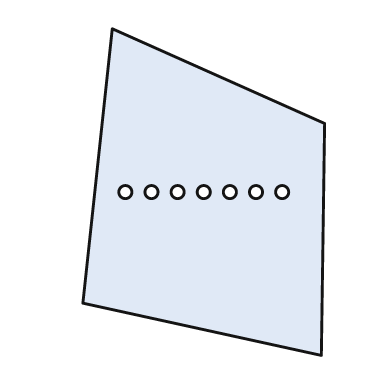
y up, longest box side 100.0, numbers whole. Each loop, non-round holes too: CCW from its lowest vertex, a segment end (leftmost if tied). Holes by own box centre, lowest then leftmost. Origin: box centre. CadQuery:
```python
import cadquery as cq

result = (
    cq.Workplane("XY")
    .moveTo(36.0, -50.0)
    .lineTo(37.0, 21.0)
    .lineTo(-28.0, 50.0)
    .lineTo(-37.0, -34.0)
    .close()
    .moveTo(-24.0, 0.0)
    .circle(2.0)
    .moveTo(-16.0, 0.0)
    .circle(2.0)
    .moveTo(-8.0, 0.0)
    .circle(2.0)
    .moveTo(0.0, 0.0)
    .circle(2.0)
    .moveTo(8.0, 0.0)
    .circle(2.0)
    .moveTo(16.0, 0.0)
    .circle(2.0)
    .moveTo(24.0, 0.0)
    .circle(2.0)
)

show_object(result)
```